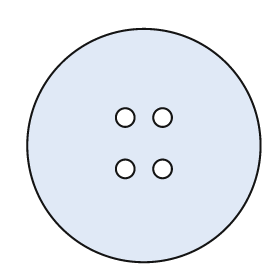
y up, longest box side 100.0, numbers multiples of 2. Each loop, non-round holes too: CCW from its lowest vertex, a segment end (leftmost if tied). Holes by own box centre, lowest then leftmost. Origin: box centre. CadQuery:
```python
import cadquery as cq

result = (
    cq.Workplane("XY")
    .moveTo(0.0, 0.0)
    .circle(50.0)
    .moveTo(-8.0, -10.0)
    .circle(4.0)
    .moveTo(8.0, -10.0)
    .circle(4.0)
    .moveTo(-8.0, 12.0)
    .circle(4.0)
    .moveTo(8.0, 12.0)
    .circle(4.0)
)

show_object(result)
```